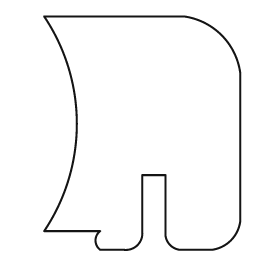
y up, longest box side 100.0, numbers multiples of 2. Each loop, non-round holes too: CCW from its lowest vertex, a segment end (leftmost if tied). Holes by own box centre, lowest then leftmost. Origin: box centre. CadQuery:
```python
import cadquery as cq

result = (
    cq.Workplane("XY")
    .moveTo(-18.0, -50.0)
    .lineTo(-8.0, -50.0)
    .threePointArc((-2.0, -48.0), (0.0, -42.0))
    .lineTo(0.0, -18.0)
    .lineTo(10.0, -18.0)
    .lineTo(10.0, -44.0)
    .threePointArc((12.0, -48.0), (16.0, -50.0))
    .lineTo(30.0, -50.0)
    .threePointArc((38.0, -46.0), (42.0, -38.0))
    .lineTo(42.0, 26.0)
    .threePointArc((34.0, 42.0), (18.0, 50.0))
    .lineTo(-42.0, 50.0)
    .threePointArc((-28.0, 4.0), (-42.0, -42.0))
    .lineTo(-18.0, -42.0)
    .threePointArc((-20.0, -46.0), (-18.0, -50.0))
    .close()
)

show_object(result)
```